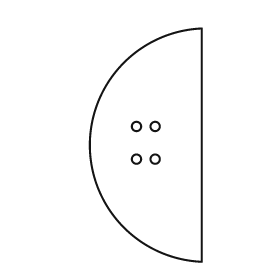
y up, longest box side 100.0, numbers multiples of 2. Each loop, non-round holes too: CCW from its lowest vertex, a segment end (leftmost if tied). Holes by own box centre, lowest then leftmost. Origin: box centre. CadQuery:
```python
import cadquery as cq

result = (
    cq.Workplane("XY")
    .moveTo(24.0, -50.0)
    .lineTo(24.0, 50.0)
    .threePointArc((-24.0, 0.0), (24.0, -50.0))
    .close()
    .moveTo(-4.0, -6.0)
    .circle(2.0)
    .moveTo(4.0, -6.0)
    .circle(2.0)
    .moveTo(-4.0, 8.0)
    .circle(2.0)
    .moveTo(4.0, 8.0)
    .circle(2.0)
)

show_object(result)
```